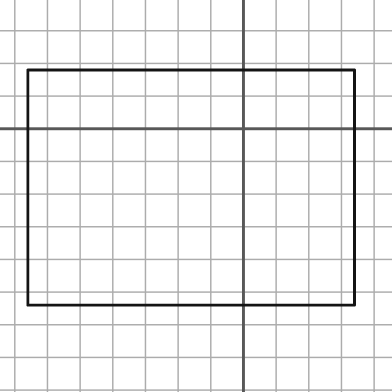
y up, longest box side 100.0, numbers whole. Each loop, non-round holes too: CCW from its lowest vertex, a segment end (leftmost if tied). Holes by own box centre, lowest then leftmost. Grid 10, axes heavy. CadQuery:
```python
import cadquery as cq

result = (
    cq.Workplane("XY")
    .moveTo(-66.0, -54.0)
    .lineTo(34.0, -54.0)
    .lineTo(34.0, 18.0)
    .lineTo(-66.0, 18.0)
    .close()
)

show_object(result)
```